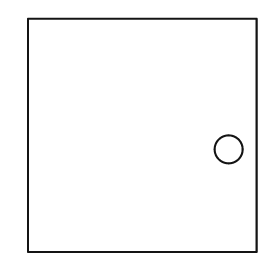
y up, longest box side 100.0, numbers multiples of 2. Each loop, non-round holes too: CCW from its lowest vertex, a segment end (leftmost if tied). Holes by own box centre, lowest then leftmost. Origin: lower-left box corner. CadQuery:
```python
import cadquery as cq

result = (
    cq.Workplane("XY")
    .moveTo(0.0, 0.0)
    .lineTo(98.0, 0.0)
    .lineTo(98.0, 100.0)
    .lineTo(0.0, 100.0)
    .close()
    .moveTo(86.0, 44.0)
    .circle(6.0)
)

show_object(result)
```